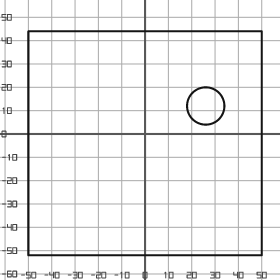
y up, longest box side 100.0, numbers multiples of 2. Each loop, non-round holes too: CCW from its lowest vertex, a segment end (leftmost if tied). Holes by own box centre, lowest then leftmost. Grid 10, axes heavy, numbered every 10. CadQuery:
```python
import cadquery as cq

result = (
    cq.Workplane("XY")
    .moveTo(-50.0, -52.0)
    .lineTo(50.0, -52.0)
    .lineTo(50.0, 44.0)
    .lineTo(-50.0, 44.0)
    .close()
    .moveTo(26.0, 12.0)
    .circle(8.0)
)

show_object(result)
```